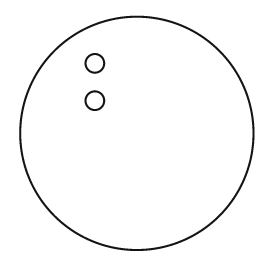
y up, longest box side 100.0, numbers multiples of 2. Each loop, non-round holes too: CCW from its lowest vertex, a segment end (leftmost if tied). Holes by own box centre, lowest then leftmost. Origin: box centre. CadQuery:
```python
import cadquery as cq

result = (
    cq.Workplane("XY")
    .moveTo(0.0, 0.0)
    .circle(50.0)
    .moveTo(-18.0, 14.0)
    .circle(4.0)
    .moveTo(-18.0, 30.0)
    .circle(4.0)
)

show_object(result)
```